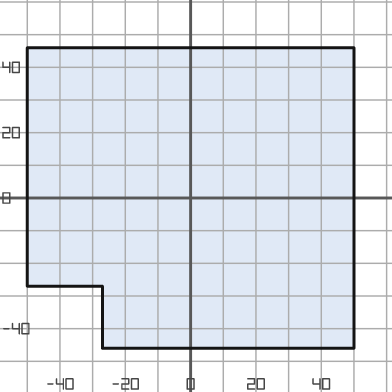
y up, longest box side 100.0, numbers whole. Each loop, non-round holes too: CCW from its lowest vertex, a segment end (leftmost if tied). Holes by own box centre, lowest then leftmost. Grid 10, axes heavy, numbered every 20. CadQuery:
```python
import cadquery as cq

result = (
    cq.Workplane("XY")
    .moveTo(-27.0, -46.0)
    .lineTo(50.0, -46.0)
    .lineTo(50.0, 46.0)
    .lineTo(-50.0, 46.0)
    .lineTo(-50.0, -27.0)
    .lineTo(-27.0, -27.0)
    .close()
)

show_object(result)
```